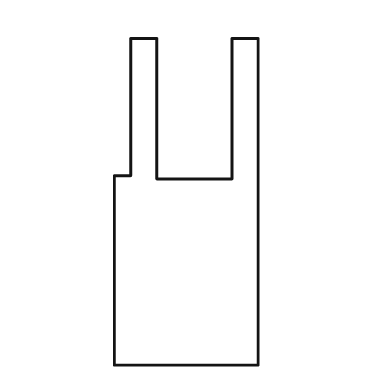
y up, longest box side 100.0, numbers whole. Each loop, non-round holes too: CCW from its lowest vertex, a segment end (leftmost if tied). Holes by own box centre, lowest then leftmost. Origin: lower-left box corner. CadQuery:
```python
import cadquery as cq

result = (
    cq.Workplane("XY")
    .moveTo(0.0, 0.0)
    .lineTo(44.0, 0.0)
    .lineTo(44.0, 100.0)
    .lineTo(36.0, 100.0)
    .lineTo(36.0, 57.0)
    .lineTo(13.0, 57.0)
    .lineTo(13.0, 100.0)
    .lineTo(5.0, 100.0)
    .lineTo(5.0, 58.0)
    .lineTo(0.0, 58.0)
    .close()
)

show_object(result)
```